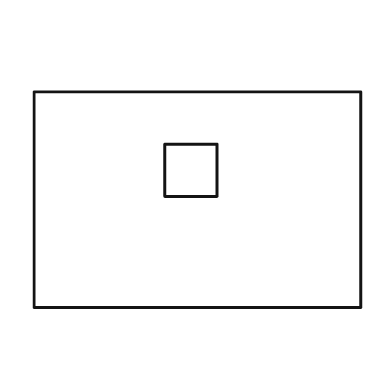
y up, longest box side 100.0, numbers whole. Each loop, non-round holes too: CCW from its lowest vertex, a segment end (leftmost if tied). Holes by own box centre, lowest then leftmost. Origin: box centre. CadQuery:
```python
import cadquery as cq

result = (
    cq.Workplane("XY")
    .moveTo(-50.0, -33.0)
    .lineTo(50.0, -33.0)
    .lineTo(50.0, 33.0)
    .lineTo(-50.0, 33.0)
    .close()
    .moveTo(-10.0, 1.0)
    .lineTo(6.0, 1.0)
    .lineTo(6.0, 17.0)
    .lineTo(-10.0, 17.0)
    .close()
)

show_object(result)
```